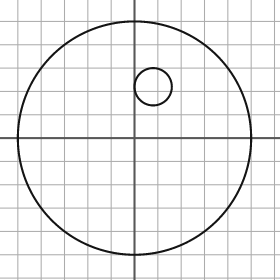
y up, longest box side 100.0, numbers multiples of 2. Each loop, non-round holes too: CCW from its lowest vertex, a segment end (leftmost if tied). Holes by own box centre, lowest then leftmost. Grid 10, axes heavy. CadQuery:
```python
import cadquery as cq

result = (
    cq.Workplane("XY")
    .moveTo(0.0, 0.0)
    .circle(50.0)
    .moveTo(8.0, 22.0)
    .circle(8.0)
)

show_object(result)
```